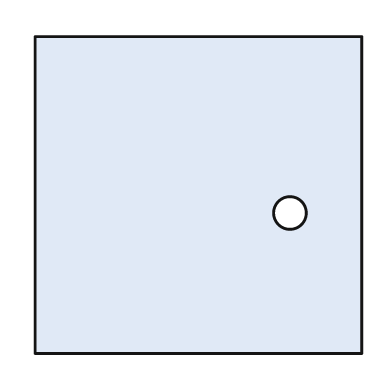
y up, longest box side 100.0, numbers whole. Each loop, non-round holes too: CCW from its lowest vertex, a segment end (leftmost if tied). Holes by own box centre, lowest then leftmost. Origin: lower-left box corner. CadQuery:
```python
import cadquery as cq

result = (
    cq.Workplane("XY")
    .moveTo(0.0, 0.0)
    .lineTo(100.0, 0.0)
    .lineTo(100.0, 97.0)
    .lineTo(0.0, 97.0)
    .close()
    .moveTo(78.0, 43.0)
    .circle(5.0)
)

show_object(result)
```